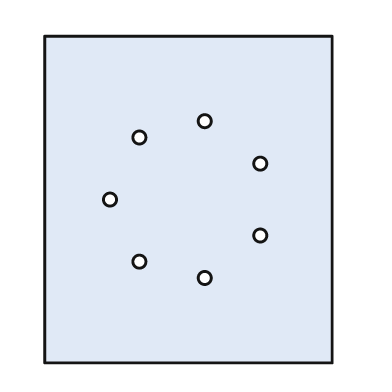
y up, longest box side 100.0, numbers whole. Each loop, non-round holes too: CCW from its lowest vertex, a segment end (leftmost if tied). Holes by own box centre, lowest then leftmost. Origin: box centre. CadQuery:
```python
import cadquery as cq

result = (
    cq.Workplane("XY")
    .moveTo(-44.0, -50.0)
    .lineTo(44.0, -50.0)
    .lineTo(44.0, 50.0)
    .lineTo(-44.0, 50.0)
    .close()
    .moveTo(5.0, -24.0)
    .circle(2.0)
    .moveTo(-15.0, -19.0)
    .circle(2.0)
    .moveTo(22.0, -11.0)
    .circle(2.0)
    .moveTo(-24.0, 0.0)
    .circle(2.0)
    .moveTo(22.0, 11.0)
    .circle(2.0)
    .moveTo(-15.0, 19.0)
    .circle(2.0)
    .moveTo(5.0, 24.0)
    .circle(2.0)
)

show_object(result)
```